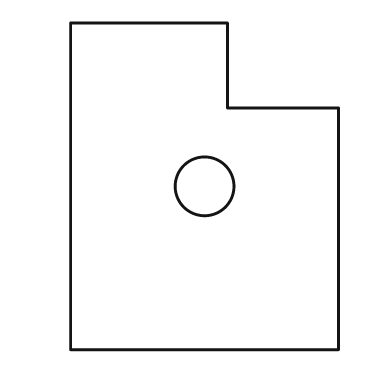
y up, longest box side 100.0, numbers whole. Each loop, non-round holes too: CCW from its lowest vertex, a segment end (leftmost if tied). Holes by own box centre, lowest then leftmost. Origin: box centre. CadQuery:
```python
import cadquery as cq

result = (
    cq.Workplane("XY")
    .moveTo(-41.0, -50.0)
    .lineTo(41.0, -50.0)
    .lineTo(41.0, 24.0)
    .lineTo(7.0, 24.0)
    .lineTo(7.0, 50.0)
    .lineTo(-41.0, 50.0)
    .close()
    .moveTo(0.0, 0.0)
    .circle(9.0)
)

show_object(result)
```